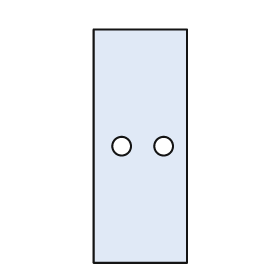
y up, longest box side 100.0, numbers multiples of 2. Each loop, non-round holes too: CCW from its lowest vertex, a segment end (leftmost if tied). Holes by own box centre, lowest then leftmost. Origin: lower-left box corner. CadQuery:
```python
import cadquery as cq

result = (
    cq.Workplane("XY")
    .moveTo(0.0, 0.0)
    .lineTo(40.0, 0.0)
    .lineTo(40.0, 100.0)
    .lineTo(0.0, 100.0)
    .close()
    .moveTo(12.0, 50.0)
    .circle(4.0)
    .moveTo(30.0, 50.0)
    .circle(4.0)
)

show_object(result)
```